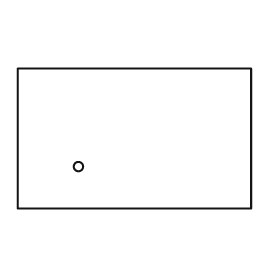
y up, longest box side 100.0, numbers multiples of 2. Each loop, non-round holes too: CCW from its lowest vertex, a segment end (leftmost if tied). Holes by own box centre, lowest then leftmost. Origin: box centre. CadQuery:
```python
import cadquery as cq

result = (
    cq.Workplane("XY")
    .moveTo(-50.0, -30.0)
    .lineTo(50.0, -30.0)
    .lineTo(50.0, 30.0)
    .lineTo(-50.0, 30.0)
    .close()
    .moveTo(-24.0, -12.0)
    .circle(2.0)
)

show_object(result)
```